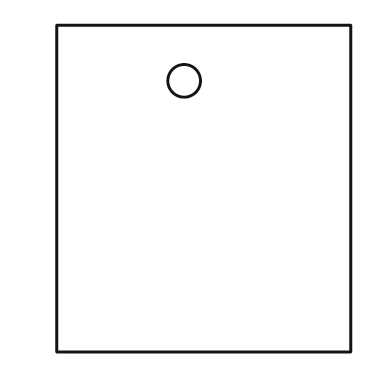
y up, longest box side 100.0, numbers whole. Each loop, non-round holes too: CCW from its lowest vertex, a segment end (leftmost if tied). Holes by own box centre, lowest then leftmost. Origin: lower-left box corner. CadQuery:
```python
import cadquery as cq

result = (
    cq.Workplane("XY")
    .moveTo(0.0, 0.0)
    .lineTo(90.0, 0.0)
    .lineTo(90.0, 100.0)
    .lineTo(0.0, 100.0)
    .close()
    .moveTo(39.0, 83.0)
    .circle(5.0)
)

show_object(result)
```